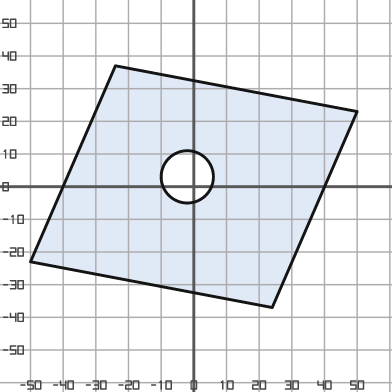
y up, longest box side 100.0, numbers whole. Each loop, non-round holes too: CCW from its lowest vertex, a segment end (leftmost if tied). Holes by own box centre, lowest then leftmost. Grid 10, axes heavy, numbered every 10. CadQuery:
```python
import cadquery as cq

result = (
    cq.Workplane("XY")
    .moveTo(24.0, -37.0)
    .lineTo(50.0, 23.0)
    .lineTo(-24.0, 37.0)
    .lineTo(-50.0, -23.0)
    .close()
    .moveTo(-2.0, 3.0)
    .circle(8.0)
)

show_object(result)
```